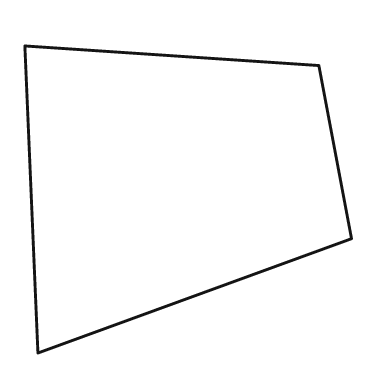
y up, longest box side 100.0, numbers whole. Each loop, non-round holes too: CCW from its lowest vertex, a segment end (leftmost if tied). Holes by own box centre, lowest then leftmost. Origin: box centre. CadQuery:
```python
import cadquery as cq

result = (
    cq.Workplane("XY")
    .moveTo(-46.0, -47.0)
    .lineTo(50.0, -12.0)
    .lineTo(40.0, 41.0)
    .lineTo(-50.0, 47.0)
    .close()
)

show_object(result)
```